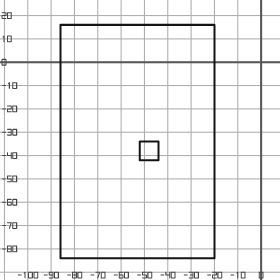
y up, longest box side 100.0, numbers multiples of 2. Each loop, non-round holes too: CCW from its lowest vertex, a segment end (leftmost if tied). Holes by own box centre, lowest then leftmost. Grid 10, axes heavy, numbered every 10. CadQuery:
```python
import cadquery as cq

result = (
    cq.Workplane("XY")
    .moveTo(-86.0, -84.0)
    .lineTo(-20.0, -84.0)
    .lineTo(-20.0, 16.0)
    .lineTo(-86.0, 16.0)
    .close()
    .moveTo(-52.0, -42.0)
    .lineTo(-44.0, -42.0)
    .lineTo(-44.0, -34.0)
    .lineTo(-52.0, -34.0)
    .close()
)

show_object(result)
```